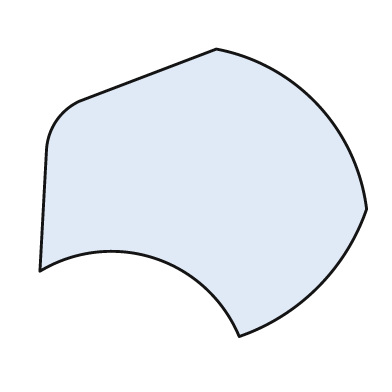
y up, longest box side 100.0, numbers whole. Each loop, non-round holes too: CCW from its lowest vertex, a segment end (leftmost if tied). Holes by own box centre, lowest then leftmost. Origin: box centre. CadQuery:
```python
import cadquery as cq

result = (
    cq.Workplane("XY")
    .moveTo(11.0, -44.0)
    .threePointArc((35.0, -29.0), (50.0, -5.0))
    .threePointArc((35.0, 27.0), (4.0, 44.0))
    .lineTo(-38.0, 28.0)
    .threePointArc((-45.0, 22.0), (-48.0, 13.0))
    .lineTo(-50.0, -24.0)
    .threePointArc((-15.0, -20.0), (11.0, -44.0))
    .close()
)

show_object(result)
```